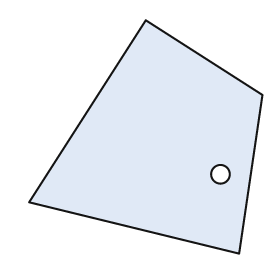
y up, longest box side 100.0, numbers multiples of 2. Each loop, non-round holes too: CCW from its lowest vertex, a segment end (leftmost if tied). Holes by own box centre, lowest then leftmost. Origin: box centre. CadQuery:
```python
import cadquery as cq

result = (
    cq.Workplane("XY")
    .moveTo(40.0, -50.0)
    .lineTo(50.0, 18.0)
    .lineTo(0.0, 50.0)
    .lineTo(-50.0, -28.0)
    .close()
    .moveTo(32.0, -16.0)
    .circle(4.0)
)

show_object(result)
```